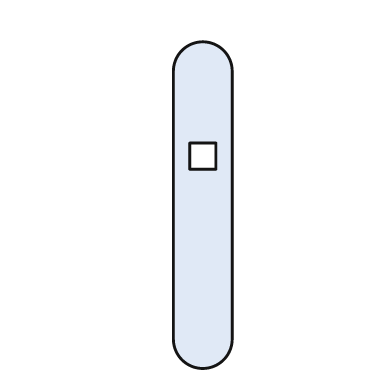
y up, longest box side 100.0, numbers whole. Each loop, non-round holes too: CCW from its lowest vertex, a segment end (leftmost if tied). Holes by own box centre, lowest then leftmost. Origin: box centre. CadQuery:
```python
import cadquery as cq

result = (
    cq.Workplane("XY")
    .moveTo(-9.0, -41.0)
    .threePointArc((0.0, -50.0), (9.0, -41.0))
    .lineTo(9.0, 41.0)
    .threePointArc((0.0, 50.0), (-9.0, 41.0))
    .close()
    .moveTo(-4.0, 11.0)
    .lineTo(4.0, 11.0)
    .lineTo(4.0, 19.0)
    .lineTo(-4.0, 19.0)
    .close()
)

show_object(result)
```